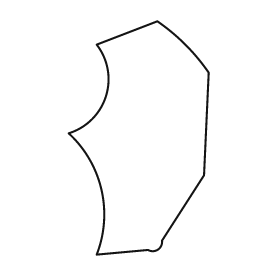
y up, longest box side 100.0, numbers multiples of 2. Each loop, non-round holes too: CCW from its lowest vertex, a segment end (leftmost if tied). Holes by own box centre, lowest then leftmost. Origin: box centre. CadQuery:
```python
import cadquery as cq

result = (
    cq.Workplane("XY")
    .moveTo(-18.0, -50.0)
    .lineTo(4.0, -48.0)
    .threePointArc((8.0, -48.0), (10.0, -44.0))
    .lineTo(28.0, -16.0)
    .lineTo(30.0, 28.0)
    .threePointArc((20.0, 40.0), (8.0, 50.0))
    .lineTo(-18.0, 40.0)
    .threePointArc((-14.0, 18.0), (-30.0, 2.0))
    .threePointArc((-16.0, -22.0), (-18.0, -50.0))
    .close()
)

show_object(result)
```